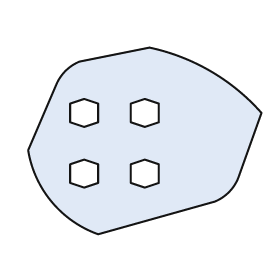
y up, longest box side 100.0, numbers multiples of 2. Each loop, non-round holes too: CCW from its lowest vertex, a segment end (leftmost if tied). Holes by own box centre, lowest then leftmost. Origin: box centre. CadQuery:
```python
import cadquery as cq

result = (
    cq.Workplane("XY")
    .moveTo(-20.0, -40.0)
    .lineTo(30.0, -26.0)
    .threePointArc((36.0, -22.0), (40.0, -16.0))
    .lineTo(50.0, 12.0)
    .threePointArc((28.0, 30.0), (2.0, 40.0))
    .lineTo(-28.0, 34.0)
    .threePointArc((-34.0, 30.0), (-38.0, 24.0))
    .lineTo(-50.0, -4.0)
    .threePointArc((-40.0, -26.0), (-20.0, -40.0))
    .close()
    .moveTo(-26.0, -20.0)
    .lineTo(-20.0, -18.0)
    .lineTo(-20.0, -10.0)
    .lineTo(-26.0, -8.0)
    .lineTo(-32.0, -10.0)
    .lineTo(-32.0, -18.0)
    .close()
    .moveTo(0.0, -20.0)
    .lineTo(6.0, -18.0)
    .lineTo(6.0, -10.0)
    .lineTo(0.0, -8.0)
    .lineTo(-6.0, -10.0)
    .lineTo(-6.0, -18.0)
    .close()
    .moveTo(-26.0, 6.0)
    .lineTo(-20.0, 8.0)
    .lineTo(-20.0, 16.0)
    .lineTo(-26.0, 18.0)
    .lineTo(-32.0, 16.0)
    .lineTo(-32.0, 8.0)
    .close()
    .moveTo(0.0, 6.0)
    .lineTo(6.0, 8.0)
    .lineTo(6.0, 16.0)
    .lineTo(0.0, 18.0)
    .lineTo(-6.0, 16.0)
    .lineTo(-6.0, 8.0)
    .close()
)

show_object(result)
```